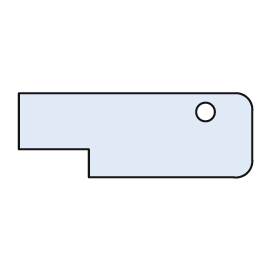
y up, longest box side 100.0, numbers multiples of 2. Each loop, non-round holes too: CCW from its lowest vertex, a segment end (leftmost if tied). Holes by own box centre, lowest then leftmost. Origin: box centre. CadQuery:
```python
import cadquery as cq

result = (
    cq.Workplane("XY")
    .moveTo(-20.0, -18.0)
    .lineTo(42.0, -18.0)
    .threePointArc((48.0, -16.0), (50.0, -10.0))
    .lineTo(50.0, 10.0)
    .threePointArc((48.0, 16.0), (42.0, 18.0))
    .lineTo(-50.0, 18.0)
    .lineTo(-50.0, -6.0)
    .lineTo(-20.0, -6.0)
    .close()
    .moveTo(30.0, 10.0)
    .circle(4.0)
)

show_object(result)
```